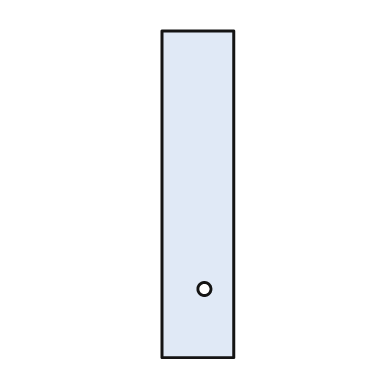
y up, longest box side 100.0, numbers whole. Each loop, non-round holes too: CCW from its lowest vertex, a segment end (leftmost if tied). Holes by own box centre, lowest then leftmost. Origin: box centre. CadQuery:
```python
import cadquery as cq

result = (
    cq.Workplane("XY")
    .moveTo(-11.0, -50.0)
    .lineTo(11.0, -50.0)
    .lineTo(11.0, 50.0)
    .lineTo(-11.0, 50.0)
    .close()
    .moveTo(2.0, -29.0)
    .circle(2.0)
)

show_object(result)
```